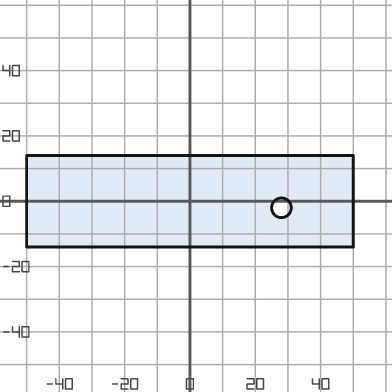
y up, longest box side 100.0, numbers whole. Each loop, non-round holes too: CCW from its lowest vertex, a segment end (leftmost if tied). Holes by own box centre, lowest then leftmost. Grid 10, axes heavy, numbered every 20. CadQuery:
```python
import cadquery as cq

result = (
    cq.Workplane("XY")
    .moveTo(-50.0, -14.0)
    .lineTo(50.0, -14.0)
    .lineTo(50.0, 14.0)
    .lineTo(-50.0, 14.0)
    .close()
    .moveTo(28.0, -2.0)
    .circle(3.0)
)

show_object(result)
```